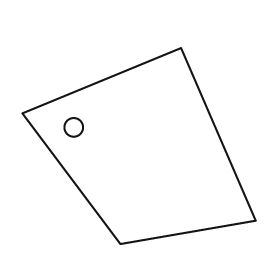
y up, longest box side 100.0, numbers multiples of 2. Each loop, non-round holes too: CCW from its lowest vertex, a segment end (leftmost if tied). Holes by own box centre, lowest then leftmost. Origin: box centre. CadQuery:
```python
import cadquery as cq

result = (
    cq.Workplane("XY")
    .moveTo(-8.0, -42.0)
    .lineTo(50.0, -32.0)
    .lineTo(18.0, 42.0)
    .lineTo(-50.0, 14.0)
    .close()
    .moveTo(-28.0, 8.0)
    .circle(4.0)
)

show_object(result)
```